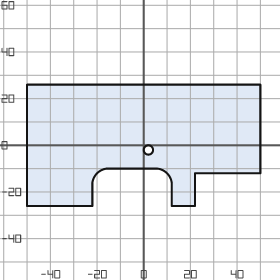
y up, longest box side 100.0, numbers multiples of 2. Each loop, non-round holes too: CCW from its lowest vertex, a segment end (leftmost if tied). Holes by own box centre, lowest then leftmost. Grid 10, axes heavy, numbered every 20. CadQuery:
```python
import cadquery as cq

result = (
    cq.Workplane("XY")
    .moveTo(-50.0, -26.0)
    .lineTo(-22.0, -26.0)
    .lineTo(-22.0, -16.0)
    .threePointArc((-20.0, -12.0), (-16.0, -10.0))
    .lineTo(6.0, -10.0)
    .threePointArc((10.0, -12.0), (12.0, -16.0))
    .lineTo(12.0, -26.0)
    .lineTo(22.0, -26.0)
    .lineTo(22.0, -12.0)
    .lineTo(50.0, -12.0)
    .lineTo(50.0, 26.0)
    .lineTo(-50.0, 26.0)
    .close()
    .moveTo(2.0, -2.0)
    .circle(2.0)
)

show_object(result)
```